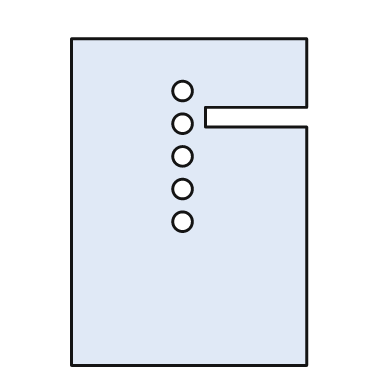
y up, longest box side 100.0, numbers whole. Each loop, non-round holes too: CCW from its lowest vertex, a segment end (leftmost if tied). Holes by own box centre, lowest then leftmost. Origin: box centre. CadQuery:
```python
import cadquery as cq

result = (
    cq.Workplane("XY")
    .moveTo(-36.0, -50.0)
    .lineTo(36.0, -50.0)
    .lineTo(36.0, 23.0)
    .lineTo(5.0, 23.0)
    .lineTo(5.0, 29.0)
    .lineTo(36.0, 29.0)
    .lineTo(36.0, 50.0)
    .lineTo(-36.0, 50.0)
    .close()
    .moveTo(-2.0, -6.0)
    .circle(3.0)
    .moveTo(-2.0, 4.0)
    .circle(3.0)
    .moveTo(-2.0, 14.0)
    .circle(3.0)
    .moveTo(-2.0, 24.0)
    .circle(3.0)
    .moveTo(-2.0, 34.0)
    .circle(3.0)
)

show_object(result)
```